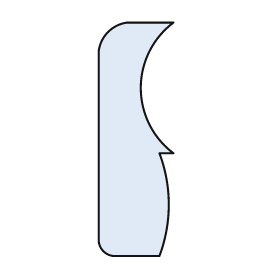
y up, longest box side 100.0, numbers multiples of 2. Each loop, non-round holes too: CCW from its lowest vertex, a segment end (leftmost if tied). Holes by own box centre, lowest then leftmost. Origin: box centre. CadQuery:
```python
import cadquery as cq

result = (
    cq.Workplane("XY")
    .moveTo(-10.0, -50.0)
    .lineTo(10.0, -50.0)
    .threePointArc((14.0, -28.0), (10.0, -6.0))
    .lineTo(16.0, -6.0)
    .threePointArc((2.0, 22.0), (16.0, 50.0))
    .lineTo(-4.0, 50.0)
    .threePointArc((-12.0, 46.0), (-16.0, 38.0))
    .lineTo(-16.0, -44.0)
    .threePointArc((-14.0, -48.0), (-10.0, -50.0))
    .close()
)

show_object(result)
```